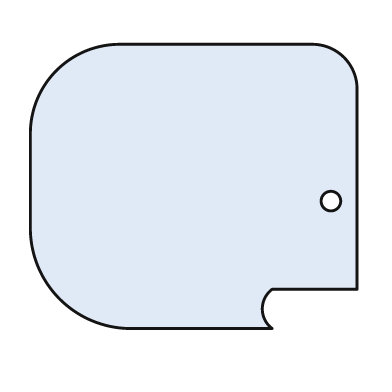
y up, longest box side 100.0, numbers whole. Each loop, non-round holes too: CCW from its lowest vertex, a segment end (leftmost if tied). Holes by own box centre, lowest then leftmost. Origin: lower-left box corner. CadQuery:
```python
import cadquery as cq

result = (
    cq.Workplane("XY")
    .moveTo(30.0, 0.0)
    .lineTo(74.0, 0.0)
    .threePointArc((71.0, 6.0), (74.0, 12.0))
    .lineTo(100.0, 12.0)
    .lineTo(100.0, 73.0)
    .threePointArc((96.0, 83.0), (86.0, 87.0))
    .lineTo(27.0, 87.0)
    .threePointArc((8.0, 79.0), (0.0, 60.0))
    .lineTo(0.0, 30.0)
    .threePointArc((9.0, 9.0), (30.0, 0.0))
    .close()
    .moveTo(92.0, 39.0)
    .circle(3.0)
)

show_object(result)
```